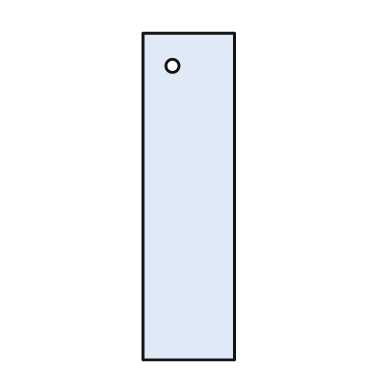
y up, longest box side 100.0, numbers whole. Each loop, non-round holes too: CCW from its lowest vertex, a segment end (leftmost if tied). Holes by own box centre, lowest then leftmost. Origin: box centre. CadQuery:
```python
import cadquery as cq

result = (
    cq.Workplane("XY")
    .moveTo(-14.0, -50.0)
    .lineTo(14.0, -50.0)
    .lineTo(14.0, 50.0)
    .lineTo(-14.0, 50.0)
    .close()
    .moveTo(-5.0, 40.0)
    .circle(2.0)
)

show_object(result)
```